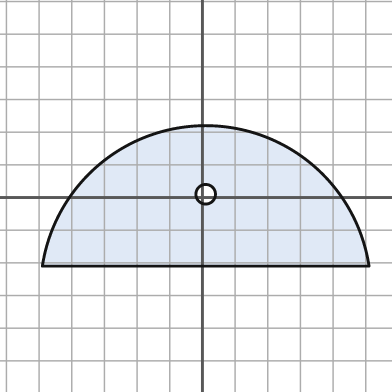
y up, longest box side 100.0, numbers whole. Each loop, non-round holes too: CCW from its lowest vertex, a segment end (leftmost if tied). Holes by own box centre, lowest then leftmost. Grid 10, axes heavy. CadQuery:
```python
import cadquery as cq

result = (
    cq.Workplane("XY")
    .moveTo(-49.0, -21.0)
    .lineTo(51.0, -21.0)
    .threePointArc((1.0, 22.0), (-49.0, -21.0))
    .close()
    .moveTo(1.0, 1.0)
    .circle(3.0)
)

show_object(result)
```